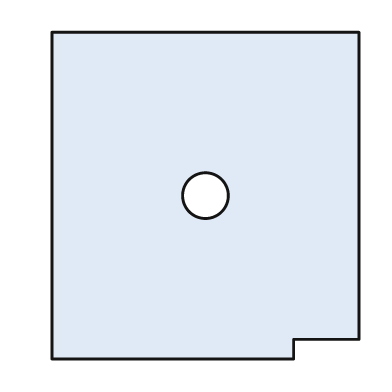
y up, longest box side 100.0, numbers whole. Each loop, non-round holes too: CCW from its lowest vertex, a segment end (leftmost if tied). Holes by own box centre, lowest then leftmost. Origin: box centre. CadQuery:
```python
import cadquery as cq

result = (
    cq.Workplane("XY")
    .moveTo(-47.0, -50.0)
    .lineTo(27.0, -50.0)
    .lineTo(27.0, -44.0)
    .lineTo(47.0, -44.0)
    .lineTo(47.0, 50.0)
    .lineTo(-47.0, 50.0)
    .close()
    .moveTo(0.0, 0.0)
    .circle(7.0)
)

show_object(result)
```